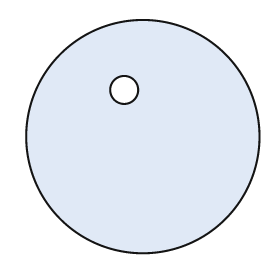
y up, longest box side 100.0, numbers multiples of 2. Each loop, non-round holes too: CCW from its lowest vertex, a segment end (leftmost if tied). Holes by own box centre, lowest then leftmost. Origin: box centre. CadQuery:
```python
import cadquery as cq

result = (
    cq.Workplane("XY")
    .moveTo(0.0, 0.0)
    .circle(50.0)
    .moveTo(-8.0, 20.0)
    .circle(6.0)
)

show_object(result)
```